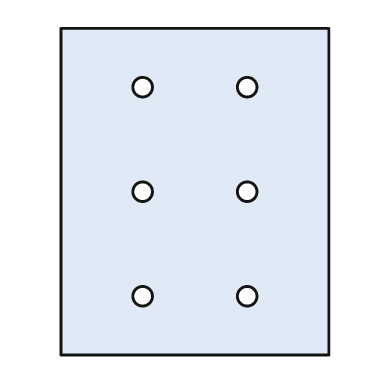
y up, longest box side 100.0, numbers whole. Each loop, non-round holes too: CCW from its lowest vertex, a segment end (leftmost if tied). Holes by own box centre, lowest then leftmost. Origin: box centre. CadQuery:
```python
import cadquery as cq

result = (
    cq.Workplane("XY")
    .moveTo(-41.0, -50.0)
    .lineTo(41.0, -50.0)
    .lineTo(41.0, 50.0)
    .lineTo(-41.0, 50.0)
    .close()
    .moveTo(-16.0, -32.0)
    .circle(3.0)
    .moveTo(16.0, -32.0)
    .circle(3.0)
    .moveTo(-16.0, 0.0)
    .circle(3.0)
    .moveTo(16.0, 0.0)
    .circle(3.0)
    .moveTo(-16.0, 32.0)
    .circle(3.0)
    .moveTo(16.0, 32.0)
    .circle(3.0)
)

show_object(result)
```